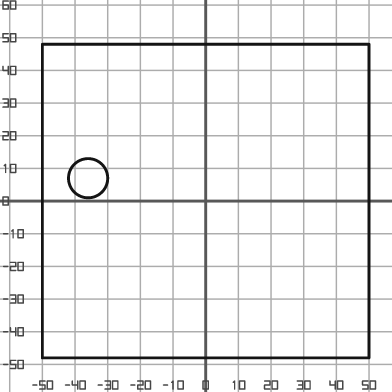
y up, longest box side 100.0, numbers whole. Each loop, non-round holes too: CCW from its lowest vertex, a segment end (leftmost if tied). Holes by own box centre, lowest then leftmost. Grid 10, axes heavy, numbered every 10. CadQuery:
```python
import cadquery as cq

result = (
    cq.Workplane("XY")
    .moveTo(-50.0, -48.0)
    .lineTo(50.0, -48.0)
    .lineTo(50.0, 48.0)
    .lineTo(-50.0, 48.0)
    .close()
    .moveTo(-36.0, 7.0)
    .circle(6.0)
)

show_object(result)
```